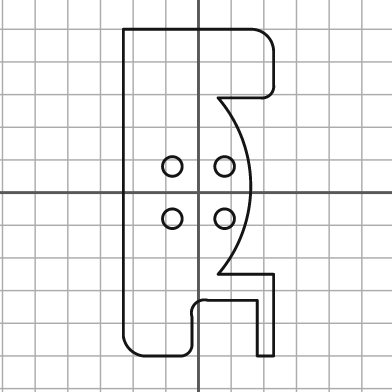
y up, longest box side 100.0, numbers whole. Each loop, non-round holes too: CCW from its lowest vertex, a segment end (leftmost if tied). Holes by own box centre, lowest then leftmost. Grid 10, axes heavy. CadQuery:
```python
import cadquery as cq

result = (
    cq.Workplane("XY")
    .moveTo(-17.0, -50.0)
    .lineTo(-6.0, -50.0)
    .threePointArc((-3.0, -49.0), (-2.0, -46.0))
    .lineTo(-2.0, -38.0)
    .threePointArc((-1.0, -34.0), (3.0, -33.0))
    .lineTo(18.0, -33.0)
    .lineTo(18.0, -50.0)
    .lineTo(23.0, -50.0)
    .lineTo(23.0, -25.0)
    .lineTo(6.0, -25.0)
    .threePointArc((16.0, 2.0), (6.0, 29.0))
    .lineTo(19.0, 29.0)
    .threePointArc((22.0, 30.0), (23.0, 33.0))
    .lineTo(23.0, 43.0)
    .threePointArc((21.0, 48.0), (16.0, 50.0))
    .lineTo(-23.0, 50.0)
    .lineTo(-23.0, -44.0)
    .threePointArc((-21.0, -48.0), (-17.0, -50.0))
    .close()
    .moveTo(-8.0, -8.0)
    .circle(3.0)
    .moveTo(8.0, -8.0)
    .circle(3.0)
    .moveTo(-8.0, 8.0)
    .circle(3.0)
    .moveTo(8.0, 8.0)
    .circle(3.0)
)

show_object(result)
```